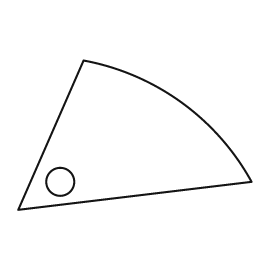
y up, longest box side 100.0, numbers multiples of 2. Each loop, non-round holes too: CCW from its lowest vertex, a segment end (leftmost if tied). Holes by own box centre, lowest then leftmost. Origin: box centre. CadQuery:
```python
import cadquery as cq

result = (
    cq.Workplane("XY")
    .moveTo(-50.0, -32.0)
    .lineTo(50.0, -20.0)
    .threePointArc((20.0, 14.0), (-22.0, 32.0))
    .close()
    .moveTo(-32.0, -20.0)
    .circle(6.0)
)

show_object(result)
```